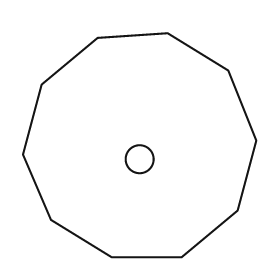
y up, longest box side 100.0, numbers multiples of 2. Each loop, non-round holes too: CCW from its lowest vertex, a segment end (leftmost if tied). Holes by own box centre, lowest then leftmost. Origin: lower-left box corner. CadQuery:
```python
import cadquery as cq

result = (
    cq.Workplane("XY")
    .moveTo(38.0, 0.0)
    .lineTo(68.0, 0.0)
    .lineTo(92.0, 20.0)
    .lineTo(100.0, 50.0)
    .lineTo(88.0, 80.0)
    .lineTo(62.0, 96.0)
    .lineTo(32.0, 94.0)
    .lineTo(8.0, 74.0)
    .lineTo(0.0, 44.0)
    .lineTo(12.0, 16.0)
    .close()
    .moveTo(50.0, 42.0)
    .circle(6.0)
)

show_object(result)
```